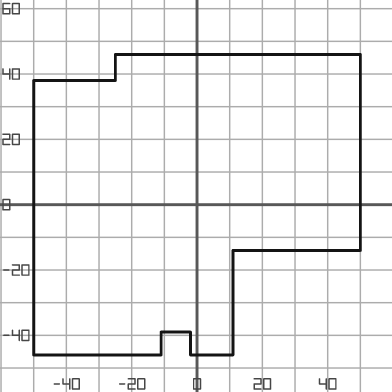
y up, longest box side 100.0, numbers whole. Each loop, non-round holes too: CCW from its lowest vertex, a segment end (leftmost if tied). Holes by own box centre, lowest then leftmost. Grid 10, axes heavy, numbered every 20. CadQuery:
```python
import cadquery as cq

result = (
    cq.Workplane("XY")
    .moveTo(-50.0, -46.0)
    .lineTo(-11.0, -46.0)
    .lineTo(-11.0, -39.0)
    .lineTo(-2.0, -39.0)
    .lineTo(-2.0, -46.0)
    .lineTo(11.0, -46.0)
    .lineTo(11.0, -14.0)
    .lineTo(50.0, -14.0)
    .lineTo(50.0, 46.0)
    .lineTo(-25.0, 46.0)
    .lineTo(-25.0, 38.0)
    .lineTo(-50.0, 38.0)
    .close()
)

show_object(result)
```